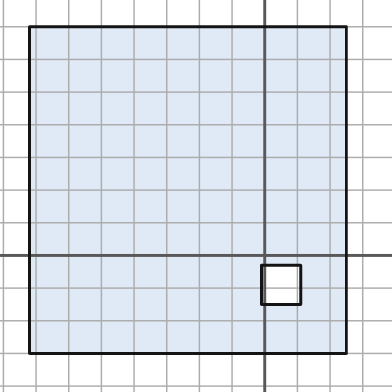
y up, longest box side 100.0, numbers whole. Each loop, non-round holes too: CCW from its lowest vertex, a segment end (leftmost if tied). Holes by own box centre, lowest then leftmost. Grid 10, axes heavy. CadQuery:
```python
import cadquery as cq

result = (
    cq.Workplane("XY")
    .moveTo(-72.0, -30.0)
    .lineTo(25.0, -30.0)
    .lineTo(25.0, 70.0)
    .lineTo(-72.0, 70.0)
    .close()
    .moveTo(-1.0, -15.0)
    .lineTo(11.0, -15.0)
    .lineTo(11.0, -3.0)
    .lineTo(-1.0, -3.0)
    .close()
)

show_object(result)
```